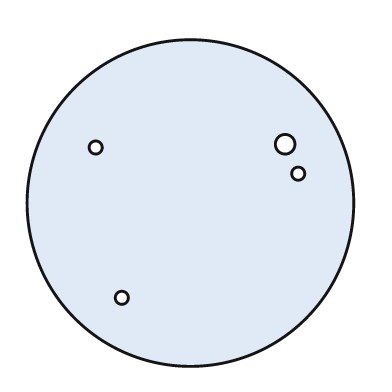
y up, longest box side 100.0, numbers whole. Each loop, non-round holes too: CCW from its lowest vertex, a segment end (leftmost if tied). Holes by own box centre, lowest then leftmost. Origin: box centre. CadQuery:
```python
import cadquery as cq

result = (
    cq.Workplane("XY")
    .moveTo(0.0, 0.0)
    .circle(50.0)
    .moveTo(-21.0, -29.0)
    .circle(2.0)
    .moveTo(33.0, 9.0)
    .circle(2.0)
    .moveTo(-29.0, 17.0)
    .circle(2.0)
    .moveTo(29.0, 18.0)
    .circle(3.0)
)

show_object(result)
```